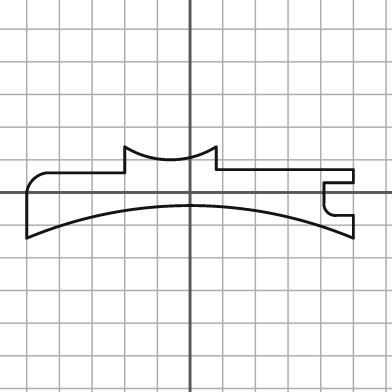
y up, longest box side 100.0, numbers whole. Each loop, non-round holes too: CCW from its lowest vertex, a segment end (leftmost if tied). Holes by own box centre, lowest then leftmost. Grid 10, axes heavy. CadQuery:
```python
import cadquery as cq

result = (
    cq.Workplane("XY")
    .moveTo(-50.0, -14.0)
    .threePointArc((0.0, -4.0), (50.0, -14.0))
    .lineTo(50.0, -7.0)
    .lineTo(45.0, -7.0)
    .threePointArc((42.0, -6.0), (41.0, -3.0))
    .lineTo(41.0, 3.0)
    .lineTo(50.0, 3.0)
    .lineTo(50.0, 7.0)
    .lineTo(8.0, 7.0)
    .lineTo(8.0, 14.0)
    .threePointArc((-6.0, 10.0), (-20.0, 14.0))
    .lineTo(-20.0, 6.0)
    .lineTo(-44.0, 6.0)
    .threePointArc((-48.0, 4.0), (-50.0, 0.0))
    .close()
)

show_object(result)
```